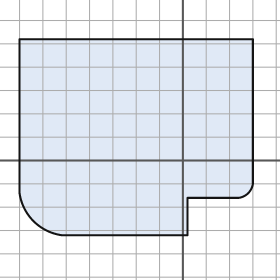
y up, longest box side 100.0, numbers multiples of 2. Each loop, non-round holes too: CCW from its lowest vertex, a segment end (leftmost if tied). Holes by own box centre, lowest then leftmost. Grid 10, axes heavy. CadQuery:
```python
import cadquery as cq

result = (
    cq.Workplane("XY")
    .moveTo(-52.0, -32.0)
    .lineTo(2.0, -32.0)
    .lineTo(2.0, -16.0)
    .lineTo(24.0, -16.0)
    .threePointArc((28.0, -14.0), (30.0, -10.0))
    .lineTo(30.0, 52.0)
    .lineTo(-70.0, 52.0)
    .lineTo(-70.0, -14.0)
    .threePointArc((-64.0, -26.0), (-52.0, -32.0))
    .close()
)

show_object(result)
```